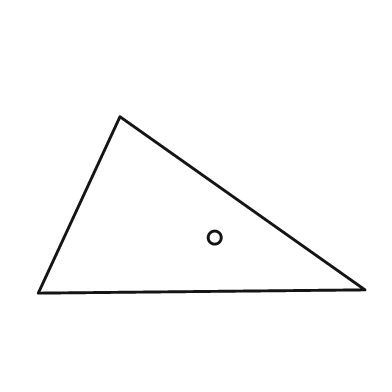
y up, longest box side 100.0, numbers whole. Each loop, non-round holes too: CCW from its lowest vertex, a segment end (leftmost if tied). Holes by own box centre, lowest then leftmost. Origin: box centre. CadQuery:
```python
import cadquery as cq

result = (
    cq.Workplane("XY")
    .moveTo(-50.0, -27.0)
    .lineTo(50.0, -26.0)
    .lineTo(-25.0, 27.0)
    .close()
    .moveTo(4.0, -10.0)
    .circle(2.0)
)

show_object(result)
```